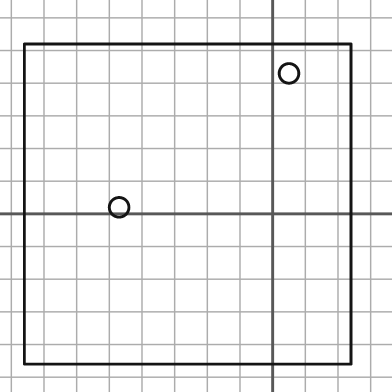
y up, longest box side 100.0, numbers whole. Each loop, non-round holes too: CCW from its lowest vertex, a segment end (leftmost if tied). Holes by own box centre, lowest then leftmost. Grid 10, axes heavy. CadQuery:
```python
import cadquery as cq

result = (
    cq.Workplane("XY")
    .moveTo(-76.0, -46.0)
    .lineTo(24.0, -46.0)
    .lineTo(24.0, 52.0)
    .lineTo(-76.0, 52.0)
    .close()
    .moveTo(-47.0, 2.0)
    .circle(3.0)
    .moveTo(5.0, 43.0)
    .circle(3.0)
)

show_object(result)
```